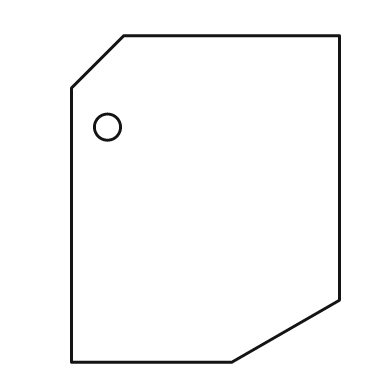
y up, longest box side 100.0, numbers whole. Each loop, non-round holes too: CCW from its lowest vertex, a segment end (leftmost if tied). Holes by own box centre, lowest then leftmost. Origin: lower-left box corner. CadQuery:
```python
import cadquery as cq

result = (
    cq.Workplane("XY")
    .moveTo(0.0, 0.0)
    .lineTo(49.0, 0.0)
    .lineTo(82.0, 19.0)
    .lineTo(82.0, 100.0)
    .lineTo(16.0, 100.0)
    .lineTo(0.0, 84.0)
    .close()
    .moveTo(11.0, 72.0)
    .circle(4.0)
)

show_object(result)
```